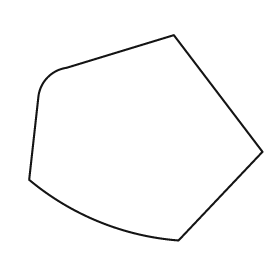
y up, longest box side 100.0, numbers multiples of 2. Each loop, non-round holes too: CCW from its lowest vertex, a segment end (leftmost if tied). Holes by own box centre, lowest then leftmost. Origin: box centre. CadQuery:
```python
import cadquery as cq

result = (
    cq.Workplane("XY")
    .moveTo(14.0, -44.0)
    .lineTo(50.0, -6.0)
    .lineTo(12.0, 44.0)
    .lineTo(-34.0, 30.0)
    .threePointArc((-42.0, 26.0), (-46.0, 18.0))
    .lineTo(-50.0, -18.0)
    .threePointArc((-20.0, -36.0), (14.0, -44.0))
    .close()
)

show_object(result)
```